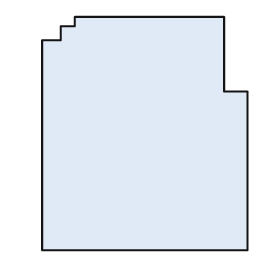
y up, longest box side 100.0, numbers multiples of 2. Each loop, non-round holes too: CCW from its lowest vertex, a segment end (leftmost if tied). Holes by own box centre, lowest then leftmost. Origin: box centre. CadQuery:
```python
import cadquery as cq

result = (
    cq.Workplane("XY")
    .moveTo(-44.0, -50.0)
    .lineTo(44.0, -50.0)
    .lineTo(44.0, 18.0)
    .lineTo(34.0, 18.0)
    .lineTo(34.0, 50.0)
    .lineTo(-30.0, 50.0)
    .lineTo(-30.0, 46.0)
    .lineTo(-36.0, 46.0)
    .lineTo(-36.0, 40.0)
    .lineTo(-44.0, 40.0)
    .close()
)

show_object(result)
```